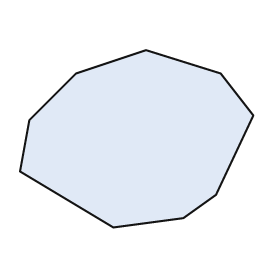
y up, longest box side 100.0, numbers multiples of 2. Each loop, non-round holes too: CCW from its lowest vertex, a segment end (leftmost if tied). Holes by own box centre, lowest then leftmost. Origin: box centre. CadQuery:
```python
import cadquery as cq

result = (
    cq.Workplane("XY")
    .moveTo(-10.0, -38.0)
    .lineTo(20.0, -34.0)
    .lineTo(34.0, -24.0)
    .lineTo(50.0, 10.0)
    .lineTo(36.0, 28.0)
    .lineTo(4.0, 38.0)
    .lineTo(-26.0, 28.0)
    .lineTo(-46.0, 8.0)
    .lineTo(-50.0, -14.0)
    .close()
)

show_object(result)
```